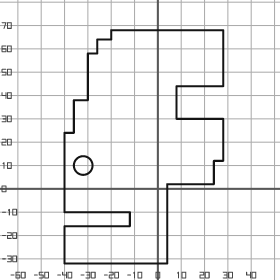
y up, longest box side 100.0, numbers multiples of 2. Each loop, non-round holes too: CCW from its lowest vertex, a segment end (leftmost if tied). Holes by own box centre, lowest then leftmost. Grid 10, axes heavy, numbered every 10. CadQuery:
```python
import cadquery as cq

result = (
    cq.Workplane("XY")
    .moveTo(-40.0, -32.0)
    .lineTo(4.0, -32.0)
    .lineTo(4.0, 2.0)
    .lineTo(24.0, 2.0)
    .lineTo(24.0, 12.0)
    .lineTo(28.0, 12.0)
    .lineTo(28.0, 30.0)
    .lineTo(8.0, 30.0)
    .lineTo(8.0, 44.0)
    .lineTo(28.0, 44.0)
    .lineTo(28.0, 68.0)
    .lineTo(-20.0, 68.0)
    .lineTo(-20.0, 64.0)
    .lineTo(-26.0, 64.0)
    .lineTo(-26.0, 58.0)
    .lineTo(-30.0, 58.0)
    .lineTo(-30.0, 38.0)
    .lineTo(-36.0, 38.0)
    .lineTo(-36.0, 24.0)
    .lineTo(-40.0, 24.0)
    .lineTo(-40.0, -10.0)
    .lineTo(-12.0, -10.0)
    .lineTo(-12.0, -16.0)
    .lineTo(-40.0, -16.0)
    .close()
    .moveTo(-32.0, 10.0)
    .circle(4.0)
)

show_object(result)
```